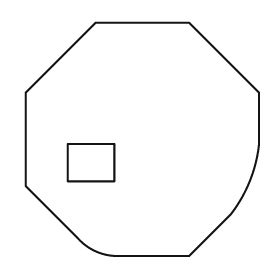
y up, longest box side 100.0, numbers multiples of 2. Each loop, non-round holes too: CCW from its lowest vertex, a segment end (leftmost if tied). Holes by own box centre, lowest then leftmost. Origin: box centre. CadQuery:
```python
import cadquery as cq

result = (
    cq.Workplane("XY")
    .moveTo(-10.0, -50.0)
    .lineTo(20.0, -50.0)
    .lineTo(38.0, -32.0)
    .threePointArc((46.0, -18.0), (50.0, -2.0))
    .lineTo(50.0, 20.0)
    .lineTo(20.0, 50.0)
    .lineTo(-20.0, 50.0)
    .lineTo(-50.0, 20.0)
    .lineTo(-50.0, -20.0)
    .lineTo(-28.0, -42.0)
    .threePointArc((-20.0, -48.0), (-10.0, -50.0))
    .close()
    .moveTo(-32.0, -18.0)
    .lineTo(-12.0, -18.0)
    .lineTo(-12.0, -2.0)
    .lineTo(-32.0, -2.0)
    .close()
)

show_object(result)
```